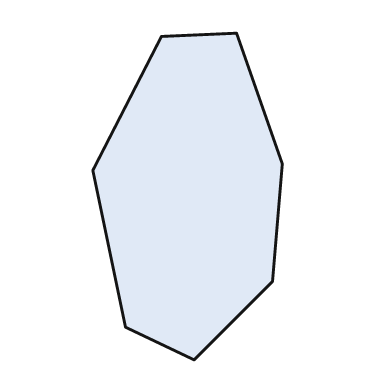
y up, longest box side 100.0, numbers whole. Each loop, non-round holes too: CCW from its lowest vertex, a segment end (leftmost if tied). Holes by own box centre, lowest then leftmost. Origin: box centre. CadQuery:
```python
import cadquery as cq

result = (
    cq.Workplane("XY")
    .moveTo(2.0, -50.0)
    .lineTo(26.0, -26.0)
    .lineTo(29.0, 10.0)
    .lineTo(15.0, 50.0)
    .lineTo(-8.0, 49.0)
    .lineTo(-29.0, 8.0)
    .lineTo(-19.0, -40.0)
    .close()
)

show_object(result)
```